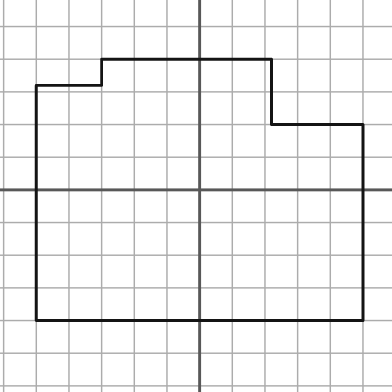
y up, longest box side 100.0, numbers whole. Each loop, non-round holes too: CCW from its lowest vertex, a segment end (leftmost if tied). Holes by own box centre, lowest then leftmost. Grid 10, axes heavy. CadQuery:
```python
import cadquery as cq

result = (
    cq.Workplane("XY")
    .moveTo(-50.0, -40.0)
    .lineTo(50.0, -40.0)
    .lineTo(50.0, 20.0)
    .lineTo(22.0, 20.0)
    .lineTo(22.0, 40.0)
    .lineTo(-30.0, 40.0)
    .lineTo(-30.0, 32.0)
    .lineTo(-50.0, 32.0)
    .close()
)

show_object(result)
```